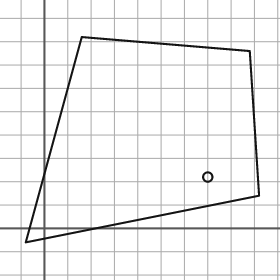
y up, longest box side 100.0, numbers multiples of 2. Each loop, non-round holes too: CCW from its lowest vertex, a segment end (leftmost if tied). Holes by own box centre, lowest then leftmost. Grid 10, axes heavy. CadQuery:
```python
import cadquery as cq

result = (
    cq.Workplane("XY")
    .moveTo(-8.0, -6.0)
    .lineTo(92.0, 14.0)
    .lineTo(88.0, 76.0)
    .lineTo(16.0, 82.0)
    .close()
    .moveTo(70.0, 22.0)
    .circle(2.0)
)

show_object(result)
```